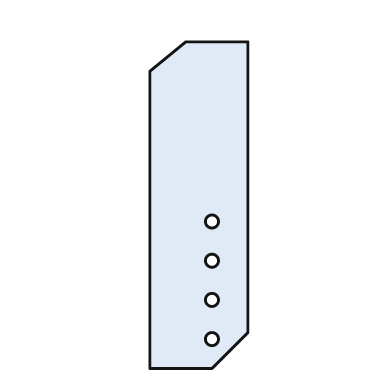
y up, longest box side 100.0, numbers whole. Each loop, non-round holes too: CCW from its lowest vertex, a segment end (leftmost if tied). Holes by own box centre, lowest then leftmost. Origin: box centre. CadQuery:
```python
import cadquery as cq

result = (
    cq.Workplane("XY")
    .moveTo(-15.0, -50.0)
    .lineTo(4.0, -50.0)
    .lineTo(15.0, -39.0)
    .lineTo(15.0, 50.0)
    .lineTo(-4.0, 50.0)
    .lineTo(-15.0, 41.0)
    .close()
    .moveTo(4.0, -41.0)
    .circle(2.0)
    .moveTo(4.0, -29.0)
    .circle(2.0)
    .moveTo(4.0, -17.0)
    .circle(2.0)
    .moveTo(4.0, -5.0)
    .circle(2.0)
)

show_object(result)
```